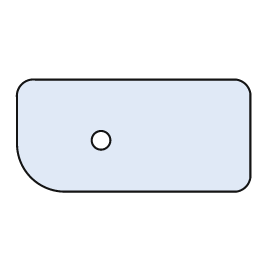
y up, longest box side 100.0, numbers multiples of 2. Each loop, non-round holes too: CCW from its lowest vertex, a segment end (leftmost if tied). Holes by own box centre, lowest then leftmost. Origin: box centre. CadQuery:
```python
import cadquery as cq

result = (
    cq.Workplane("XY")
    .moveTo(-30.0, -24.0)
    .lineTo(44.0, -24.0)
    .threePointArc((48.0, -22.0), (50.0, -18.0))
    .lineTo(50.0, 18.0)
    .threePointArc((48.0, 22.0), (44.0, 24.0))
    .lineTo(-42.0, 24.0)
    .threePointArc((-48.0, 22.0), (-50.0, 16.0))
    .lineTo(-50.0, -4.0)
    .threePointArc((-44.0, -18.0), (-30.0, -24.0))
    .close()
    .moveTo(-14.0, -2.0)
    .circle(4.0)
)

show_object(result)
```